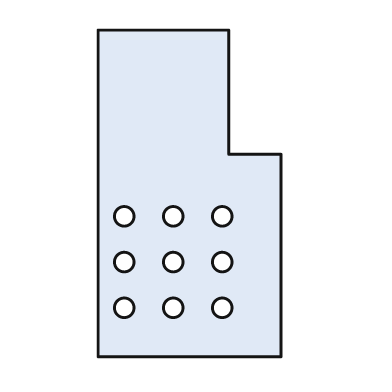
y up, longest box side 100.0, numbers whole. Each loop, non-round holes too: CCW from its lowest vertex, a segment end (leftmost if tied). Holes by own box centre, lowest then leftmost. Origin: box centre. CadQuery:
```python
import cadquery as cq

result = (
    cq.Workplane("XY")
    .moveTo(-28.0, -50.0)
    .lineTo(28.0, -50.0)
    .lineTo(28.0, 12.0)
    .lineTo(12.0, 12.0)
    .lineTo(12.0, 50.0)
    .lineTo(-28.0, 50.0)
    .close()
    .moveTo(-20.0, -35.0)
    .circle(3.0)
    .moveTo(-5.0, -35.0)
    .circle(3.0)
    .moveTo(10.0, -35.0)
    .circle(3.0)
    .moveTo(-20.0, -21.0)
    .circle(3.0)
    .moveTo(-5.0, -21.0)
    .circle(3.0)
    .moveTo(10.0, -21.0)
    .circle(3.0)
    .moveTo(-20.0, -7.0)
    .circle(3.0)
    .moveTo(-5.0, -7.0)
    .circle(3.0)
    .moveTo(10.0, -7.0)
    .circle(3.0)
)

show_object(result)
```